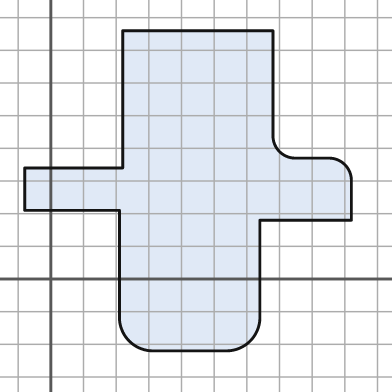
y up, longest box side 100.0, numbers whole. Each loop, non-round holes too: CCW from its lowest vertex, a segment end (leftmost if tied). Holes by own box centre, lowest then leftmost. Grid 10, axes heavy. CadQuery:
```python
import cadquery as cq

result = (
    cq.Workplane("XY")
    .moveTo(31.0, -22.0)
    .lineTo(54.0, -22.0)
    .threePointArc((61.0, -19.0), (64.0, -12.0))
    .lineTo(64.0, 18.0)
    .lineTo(92.0, 18.0)
    .lineTo(92.0, 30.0)
    .threePointArc((90.0, 35.0), (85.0, 37.0))
    .lineTo(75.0, 37.0)
    .threePointArc((70.0, 39.0), (68.0, 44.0))
    .lineTo(68.0, 76.0)
    .lineTo(22.0, 76.0)
    .lineTo(22.0, 34.0)
    .lineTo(-8.0, 34.0)
    .lineTo(-8.0, 21.0)
    .lineTo(21.0, 21.0)
    .lineTo(21.0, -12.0)
    .threePointArc((24.0, -19.0), (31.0, -22.0))
    .close()
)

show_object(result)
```